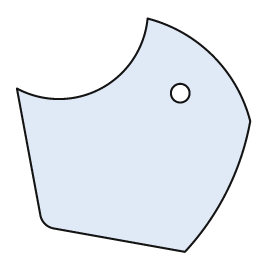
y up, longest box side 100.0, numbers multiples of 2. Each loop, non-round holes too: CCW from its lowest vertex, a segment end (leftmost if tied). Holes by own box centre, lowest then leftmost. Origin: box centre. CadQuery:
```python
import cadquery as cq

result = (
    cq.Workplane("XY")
    .moveTo(22.0, -50.0)
    .threePointArc((40.0, -24.0), (50.0, 6.0))
    .threePointArc((34.0, 34.0), (6.0, 50.0))
    .threePointArc((-14.0, 20.0), (-50.0, 20.0))
    .lineTo(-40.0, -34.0)
    .threePointArc((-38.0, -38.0), (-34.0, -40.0))
    .close()
    .moveTo(20.0, 18.0)
    .circle(4.0)
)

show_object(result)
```